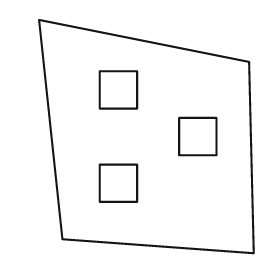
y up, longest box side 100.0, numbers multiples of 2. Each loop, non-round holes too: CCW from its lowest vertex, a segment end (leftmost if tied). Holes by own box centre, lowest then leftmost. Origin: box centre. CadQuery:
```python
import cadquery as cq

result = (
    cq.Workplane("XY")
    .moveTo(46.0, -50.0)
    .lineTo(44.0, 32.0)
    .lineTo(-46.0, 50.0)
    .lineTo(-36.0, -44.0)
    .close()
    .moveTo(-20.0, -28.0)
    .lineTo(-4.0, -28.0)
    .lineTo(-4.0, -12.0)
    .lineTo(-20.0, -12.0)
    .close()
    .moveTo(14.0, -8.0)
    .lineTo(30.0, -8.0)
    .lineTo(30.0, 8.0)
    .lineTo(14.0, 8.0)
    .close()
    .moveTo(-20.0, 12.0)
    .lineTo(-4.0, 12.0)
    .lineTo(-4.0, 28.0)
    .lineTo(-20.0, 28.0)
    .close()
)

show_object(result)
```